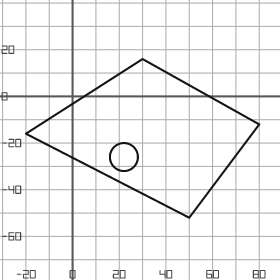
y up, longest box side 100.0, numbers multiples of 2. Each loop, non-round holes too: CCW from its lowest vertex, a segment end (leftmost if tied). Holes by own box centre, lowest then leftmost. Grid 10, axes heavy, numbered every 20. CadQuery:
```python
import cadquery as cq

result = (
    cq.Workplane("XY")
    .moveTo(50.0, -52.0)
    .lineTo(80.0, -12.0)
    .lineTo(30.0, 16.0)
    .lineTo(-20.0, -16.0)
    .close()
    .moveTo(22.0, -26.0)
    .circle(6.0)
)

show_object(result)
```